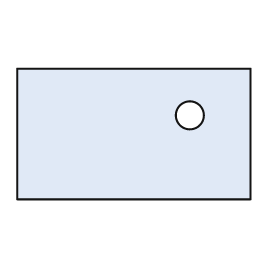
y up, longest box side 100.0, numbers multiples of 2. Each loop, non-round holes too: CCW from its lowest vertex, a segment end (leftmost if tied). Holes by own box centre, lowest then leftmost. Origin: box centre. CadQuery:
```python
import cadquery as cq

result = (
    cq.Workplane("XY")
    .moveTo(-50.0, -28.0)
    .lineTo(50.0, -28.0)
    .lineTo(50.0, 28.0)
    .lineTo(-50.0, 28.0)
    .close()
    .moveTo(24.0, 8.0)
    .circle(6.0)
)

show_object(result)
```